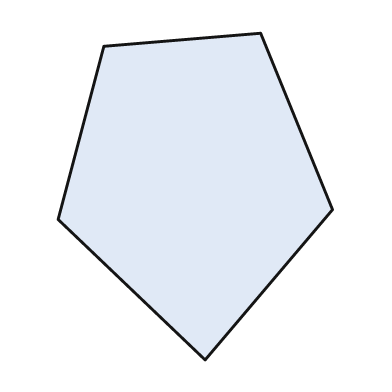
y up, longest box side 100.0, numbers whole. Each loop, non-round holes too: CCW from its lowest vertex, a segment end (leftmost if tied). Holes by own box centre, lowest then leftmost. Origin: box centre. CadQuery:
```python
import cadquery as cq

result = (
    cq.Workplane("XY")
    .moveTo(3.0, -50.0)
    .lineTo(42.0, -4.0)
    .lineTo(20.0, 50.0)
    .lineTo(-28.0, 46.0)
    .lineTo(-42.0, -7.0)
    .close()
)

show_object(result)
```